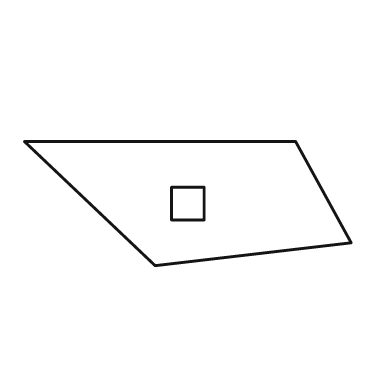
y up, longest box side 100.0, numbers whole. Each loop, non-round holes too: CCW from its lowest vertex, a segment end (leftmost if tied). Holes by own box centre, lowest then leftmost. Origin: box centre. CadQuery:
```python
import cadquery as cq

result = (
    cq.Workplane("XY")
    .moveTo(-10.0, -19.0)
    .lineTo(50.0, -12.0)
    .lineTo(33.0, 19.0)
    .lineTo(-50.0, 19.0)
    .close()
    .moveTo(-5.0, -5.0)
    .lineTo(5.0, -5.0)
    .lineTo(5.0, 5.0)
    .lineTo(-5.0, 5.0)
    .close()
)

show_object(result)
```